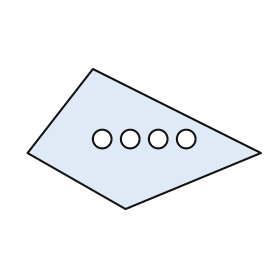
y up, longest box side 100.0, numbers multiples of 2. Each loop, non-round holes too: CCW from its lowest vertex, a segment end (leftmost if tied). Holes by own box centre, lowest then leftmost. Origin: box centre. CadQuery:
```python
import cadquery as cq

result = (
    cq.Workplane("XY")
    .moveTo(-8.0, -30.0)
    .lineTo(50.0, -6.0)
    .lineTo(-22.0, 30.0)
    .lineTo(-50.0, -6.0)
    .close()
    .moveTo(-18.0, 0.0)
    .circle(4.0)
    .moveTo(-6.0, 0.0)
    .circle(4.0)
    .moveTo(6.0, 0.0)
    .circle(4.0)
    .moveTo(18.0, 0.0)
    .circle(4.0)
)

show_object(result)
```